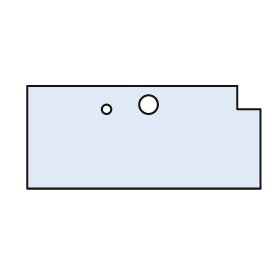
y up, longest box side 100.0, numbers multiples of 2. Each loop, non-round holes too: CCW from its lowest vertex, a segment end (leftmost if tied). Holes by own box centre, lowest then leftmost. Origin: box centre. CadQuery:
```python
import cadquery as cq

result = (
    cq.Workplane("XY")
    .moveTo(-50.0, -22.0)
    .lineTo(50.0, -22.0)
    .lineTo(50.0, 12.0)
    .lineTo(40.0, 12.0)
    .lineTo(40.0, 22.0)
    .lineTo(-50.0, 22.0)
    .close()
    .moveTo(-16.0, 12.0)
    .circle(2.0)
    .moveTo(2.0, 14.0)
    .circle(4.0)
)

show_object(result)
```